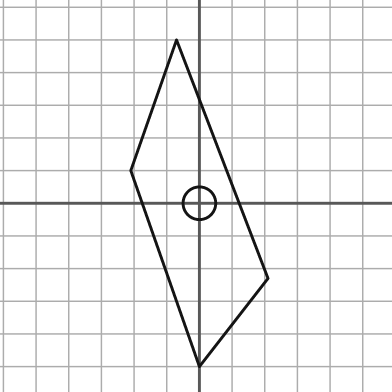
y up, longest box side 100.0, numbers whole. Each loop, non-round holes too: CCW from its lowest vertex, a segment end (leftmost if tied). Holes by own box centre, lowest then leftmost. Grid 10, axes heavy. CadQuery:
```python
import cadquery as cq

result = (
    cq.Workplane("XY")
    .moveTo(0.0, -50.0)
    .lineTo(21.0, -23.0)
    .lineTo(-7.0, 50.0)
    .lineTo(-21.0, 10.0)
    .close()
    .moveTo(0.0, 0.0)
    .circle(5.0)
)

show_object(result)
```